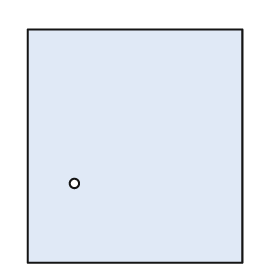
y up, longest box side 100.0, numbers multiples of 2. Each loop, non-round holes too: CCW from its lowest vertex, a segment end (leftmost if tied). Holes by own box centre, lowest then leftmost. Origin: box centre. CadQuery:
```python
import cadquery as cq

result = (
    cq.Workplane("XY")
    .moveTo(-46.0, -50.0)
    .lineTo(46.0, -50.0)
    .lineTo(46.0, 50.0)
    .lineTo(-46.0, 50.0)
    .close()
    .moveTo(-26.0, -16.0)
    .circle(2.0)
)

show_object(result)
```